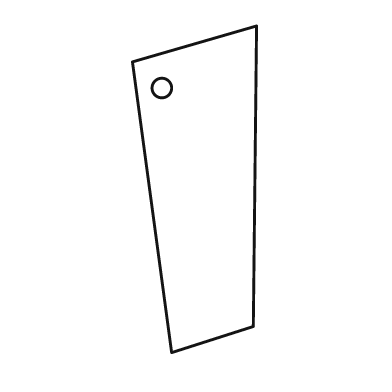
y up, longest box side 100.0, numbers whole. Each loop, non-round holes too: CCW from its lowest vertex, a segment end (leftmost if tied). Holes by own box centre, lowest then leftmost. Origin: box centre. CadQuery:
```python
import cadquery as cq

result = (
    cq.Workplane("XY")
    .moveTo(-7.0, -50.0)
    .lineTo(18.0, -42.0)
    .lineTo(19.0, 50.0)
    .lineTo(-19.0, 39.0)
    .close()
    .moveTo(-10.0, 31.0)
    .circle(3.0)
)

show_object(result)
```